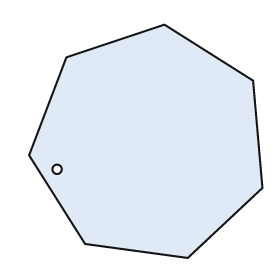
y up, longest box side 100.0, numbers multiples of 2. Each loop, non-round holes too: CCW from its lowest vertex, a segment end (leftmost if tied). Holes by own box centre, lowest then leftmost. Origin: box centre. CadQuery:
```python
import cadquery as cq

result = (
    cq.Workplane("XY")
    .moveTo(18.0, -50.0)
    .lineTo(50.0, -20.0)
    .lineTo(46.0, 26.0)
    .lineTo(8.0, 50.0)
    .lineTo(-34.0, 36.0)
    .lineTo(-50.0, -6.0)
    .lineTo(-26.0, -44.0)
    .close()
    .moveTo(-38.0, -12.0)
    .circle(2.0)
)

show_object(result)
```